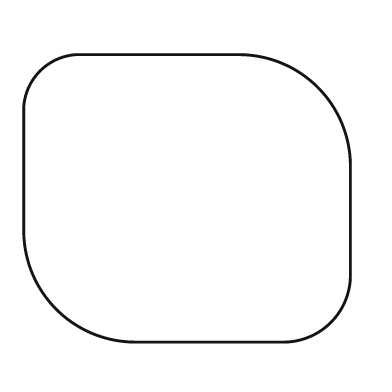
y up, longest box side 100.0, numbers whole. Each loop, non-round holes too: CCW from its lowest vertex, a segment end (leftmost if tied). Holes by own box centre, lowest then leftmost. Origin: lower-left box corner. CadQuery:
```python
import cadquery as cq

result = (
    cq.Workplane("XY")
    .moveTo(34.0, 0.0)
    .lineTo(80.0, 0.0)
    .threePointArc((94.0, 6.0), (100.0, 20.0))
    .lineTo(100.0, 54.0)
    .threePointArc((90.0, 78.0), (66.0, 88.0))
    .lineTo(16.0, 88.0)
    .threePointArc((5.0, 83.0), (0.0, 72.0))
    .lineTo(0.0, 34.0)
    .threePointArc((10.0, 10.0), (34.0, 0.0))
    .close()
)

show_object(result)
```